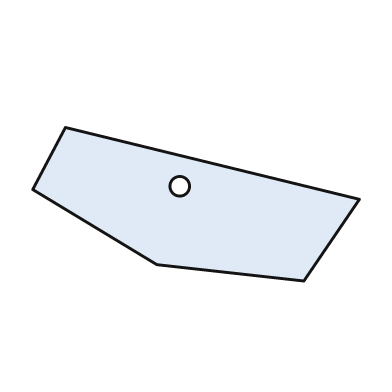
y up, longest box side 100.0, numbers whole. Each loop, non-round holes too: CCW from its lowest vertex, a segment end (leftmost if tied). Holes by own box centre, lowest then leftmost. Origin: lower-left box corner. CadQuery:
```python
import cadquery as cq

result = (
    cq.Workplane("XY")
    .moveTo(83.0, 0.0)
    .lineTo(100.0, 25.0)
    .lineTo(10.0, 47.0)
    .lineTo(0.0, 28.0)
    .lineTo(38.0, 5.0)
    .close()
    .moveTo(45.0, 29.0)
    .circle(3.0)
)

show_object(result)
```